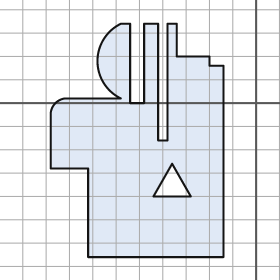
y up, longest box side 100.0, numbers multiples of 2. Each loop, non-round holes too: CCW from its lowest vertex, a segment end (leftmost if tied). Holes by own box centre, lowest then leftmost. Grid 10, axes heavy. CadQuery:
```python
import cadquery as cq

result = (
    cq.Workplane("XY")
    .moveTo(-72.0, -66.0)
    .lineTo(-14.0, -66.0)
    .lineTo(-14.0, 16.0)
    .lineTo(-20.0, 16.0)
    .lineTo(-20.0, 20.0)
    .lineTo(-34.0, 20.0)
    .lineTo(-34.0, 34.0)
    .lineTo(-38.0, 34.0)
    .lineTo(-38.0, -16.0)
    .lineTo(-42.0, -16.0)
    .lineTo(-42.0, 34.0)
    .lineTo(-48.0, 34.0)
    .lineTo(-48.0, 0.0)
    .lineTo(-54.0, 0.0)
    .lineTo(-54.0, 34.0)
    .lineTo(-58.0, 34.0)
    .threePointArc((-68.0, 18.0), (-58.0, 2.0))
    .lineTo(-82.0, 2.0)
    .threePointArc((-86.0, 0.0), (-88.0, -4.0))
    .lineTo(-88.0, -28.0)
    .lineTo(-72.0, -28.0)
    .close()
    .moveTo(-44.0, -40.0)
    .lineTo(-28.0, -40.0)
    .lineTo(-36.0, -26.0)
    .close()
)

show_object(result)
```